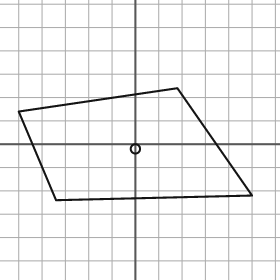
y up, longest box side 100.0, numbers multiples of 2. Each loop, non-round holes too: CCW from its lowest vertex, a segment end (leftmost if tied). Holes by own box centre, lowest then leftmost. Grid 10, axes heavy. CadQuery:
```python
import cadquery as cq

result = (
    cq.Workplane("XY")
    .moveTo(-34.0, -24.0)
    .lineTo(50.0, -22.0)
    .lineTo(18.0, 24.0)
    .lineTo(-50.0, 14.0)
    .close()
    .moveTo(0.0, -2.0)
    .circle(2.0)
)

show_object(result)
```